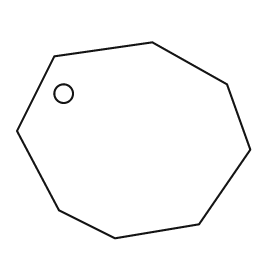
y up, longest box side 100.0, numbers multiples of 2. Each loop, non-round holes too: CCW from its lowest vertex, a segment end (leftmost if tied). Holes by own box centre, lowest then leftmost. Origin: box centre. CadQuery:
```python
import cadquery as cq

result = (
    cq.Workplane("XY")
    .moveTo(-8.0, -42.0)
    .lineTo(28.0, -36.0)
    .lineTo(50.0, -4.0)
    .lineTo(40.0, 24.0)
    .lineTo(8.0, 42.0)
    .lineTo(-34.0, 36.0)
    .lineTo(-50.0, 4.0)
    .lineTo(-32.0, -30.0)
    .close()
    .moveTo(-30.0, 20.0)
    .circle(4.0)
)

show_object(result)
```